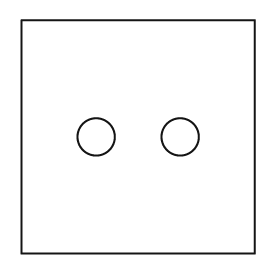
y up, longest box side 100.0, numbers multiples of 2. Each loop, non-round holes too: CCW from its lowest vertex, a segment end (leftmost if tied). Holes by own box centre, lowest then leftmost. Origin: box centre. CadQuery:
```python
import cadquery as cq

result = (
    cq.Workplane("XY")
    .moveTo(-50.0, -50.0)
    .lineTo(50.0, -50.0)
    .lineTo(50.0, 50.0)
    .lineTo(-50.0, 50.0)
    .close()
    .moveTo(-18.0, 0.0)
    .circle(8.0)
    .moveTo(18.0, 0.0)
    .circle(8.0)
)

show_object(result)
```